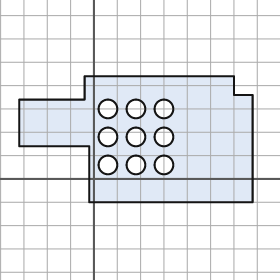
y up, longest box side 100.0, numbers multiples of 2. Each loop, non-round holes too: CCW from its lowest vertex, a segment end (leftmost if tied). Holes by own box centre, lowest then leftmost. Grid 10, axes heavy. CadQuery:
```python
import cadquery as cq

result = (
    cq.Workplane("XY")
    .moveTo(-2.0, -10.0)
    .lineTo(68.0, -10.0)
    .lineTo(68.0, 36.0)
    .lineTo(60.0, 36.0)
    .lineTo(60.0, 44.0)
    .lineTo(-4.0, 44.0)
    .lineTo(-4.0, 34.0)
    .lineTo(-32.0, 34.0)
    .lineTo(-32.0, 14.0)
    .lineTo(-2.0, 14.0)
    .close()
    .moveTo(6.0, 6.0)
    .circle(4.0)
    .moveTo(18.0, 6.0)
    .circle(4.0)
    .moveTo(30.0, 6.0)
    .circle(4.0)
    .moveTo(6.0, 18.0)
    .circle(4.0)
    .moveTo(18.0, 18.0)
    .circle(4.0)
    .moveTo(30.0, 18.0)
    .circle(4.0)
    .moveTo(6.0, 30.0)
    .circle(4.0)
    .moveTo(18.0, 30.0)
    .circle(4.0)
    .moveTo(30.0, 30.0)
    .circle(4.0)
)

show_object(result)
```